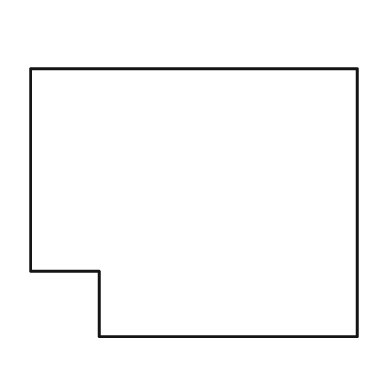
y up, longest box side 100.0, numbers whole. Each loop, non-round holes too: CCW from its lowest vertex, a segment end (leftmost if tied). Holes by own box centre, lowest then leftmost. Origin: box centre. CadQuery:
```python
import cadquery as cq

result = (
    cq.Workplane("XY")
    .moveTo(-29.0, -41.0)
    .lineTo(50.0, -41.0)
    .lineTo(50.0, 41.0)
    .lineTo(-50.0, 41.0)
    .lineTo(-50.0, -21.0)
    .lineTo(-29.0, -21.0)
    .close()
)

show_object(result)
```